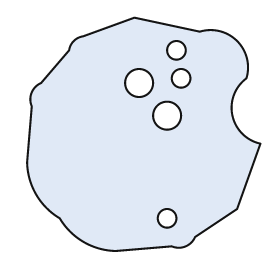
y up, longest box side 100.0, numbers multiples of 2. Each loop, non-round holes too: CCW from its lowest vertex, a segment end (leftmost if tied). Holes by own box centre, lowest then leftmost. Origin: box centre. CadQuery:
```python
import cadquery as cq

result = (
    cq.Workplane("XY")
    .moveTo(-12.0, -50.0)
    .lineTo(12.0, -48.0)
    .threePointArc((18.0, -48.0), (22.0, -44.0))
    .lineTo(40.0, -32.0)
    .lineTo(50.0, -4.0)
    .threePointArc((38.0, 8.0), (44.0, 24.0))
    .threePointArc((40.0, 40.0), (24.0, 44.0))
    .lineTo(-4.0, 50.0)
    .lineTo(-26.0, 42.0)
    .threePointArc((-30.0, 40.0), (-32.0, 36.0))
    .lineTo(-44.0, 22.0)
    .threePointArc((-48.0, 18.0), (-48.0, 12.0))
    .lineTo(-50.0, -12.0)
    .threePointArc((-46.0, -26.0), (-36.0, -36.0))
    .threePointArc((-26.0, -46.0), (-12.0, -50.0))
    .close()
    .moveTo(10.0, -36.0)
    .circle(4.0)
    .moveTo(10.0, 8.0)
    .circle(6.0)
    .moveTo(-2.0, 22.0)
    .circle(6.0)
    .moveTo(16.0, 24.0)
    .circle(4.0)
    .moveTo(14.0, 36.0)
    .circle(4.0)
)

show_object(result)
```